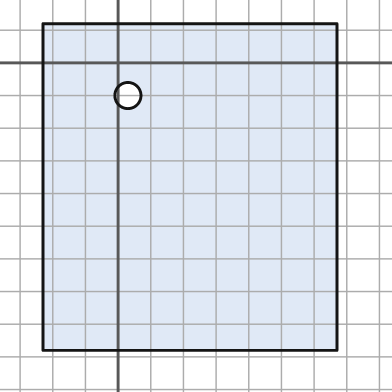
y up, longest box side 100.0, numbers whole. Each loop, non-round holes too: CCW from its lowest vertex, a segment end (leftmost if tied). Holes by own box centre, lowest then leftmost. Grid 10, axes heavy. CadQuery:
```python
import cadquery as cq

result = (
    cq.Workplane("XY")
    .moveTo(-23.0, -88.0)
    .lineTo(67.0, -88.0)
    .lineTo(67.0, 12.0)
    .lineTo(-23.0, 12.0)
    .close()
    .moveTo(3.0, -10.0)
    .circle(4.0)
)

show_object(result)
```